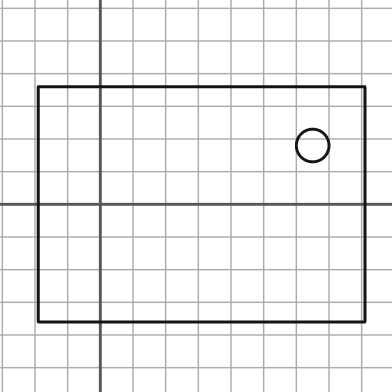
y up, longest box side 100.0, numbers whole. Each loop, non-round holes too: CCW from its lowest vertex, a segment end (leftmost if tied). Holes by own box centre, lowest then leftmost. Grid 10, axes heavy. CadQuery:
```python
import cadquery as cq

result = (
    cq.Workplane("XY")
    .moveTo(-19.0, -36.0)
    .lineTo(81.0, -36.0)
    .lineTo(81.0, 36.0)
    .lineTo(-19.0, 36.0)
    .close()
    .moveTo(65.0, 18.0)
    .circle(5.0)
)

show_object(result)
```